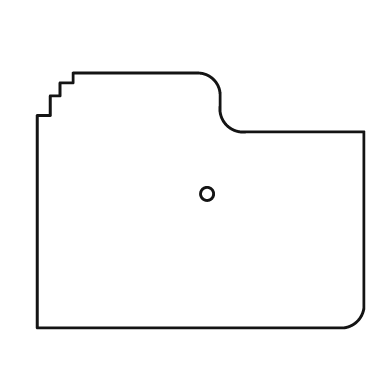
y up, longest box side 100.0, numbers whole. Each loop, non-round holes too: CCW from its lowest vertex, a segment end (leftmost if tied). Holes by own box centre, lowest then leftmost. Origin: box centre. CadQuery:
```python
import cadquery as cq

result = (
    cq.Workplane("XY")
    .moveTo(-50.0, -39.0)
    .lineTo(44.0, -39.0)
    .threePointArc((48.0, -37.0), (50.0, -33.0))
    .lineTo(50.0, 21.0)
    .lineTo(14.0, 21.0)
    .threePointArc((8.0, 23.0), (6.0, 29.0))
    .lineTo(6.0, 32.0)
    .threePointArc((4.0, 37.0), (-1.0, 39.0))
    .lineTo(-39.0, 39.0)
    .lineTo(-39.0, 36.0)
    .lineTo(-43.0, 36.0)
    .lineTo(-43.0, 32.0)
    .lineTo(-46.0, 32.0)
    .lineTo(-46.0, 26.0)
    .lineTo(-50.0, 26.0)
    .close()
    .moveTo(2.0, 2.0)
    .circle(2.0)
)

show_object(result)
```